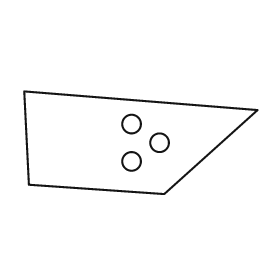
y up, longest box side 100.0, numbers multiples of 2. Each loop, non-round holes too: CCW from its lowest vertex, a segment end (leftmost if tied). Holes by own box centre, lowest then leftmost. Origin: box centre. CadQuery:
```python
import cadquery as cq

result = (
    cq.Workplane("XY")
    .moveTo(10.0, -22.0)
    .lineTo(50.0, 14.0)
    .lineTo(-50.0, 22.0)
    .lineTo(-48.0, -18.0)
    .close()
    .moveTo(-4.0, -8.0)
    .circle(4.0)
    .moveTo(8.0, 0.0)
    .circle(4.0)
    .moveTo(-4.0, 8.0)
    .circle(4.0)
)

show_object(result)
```